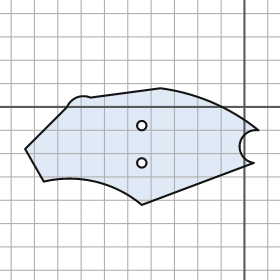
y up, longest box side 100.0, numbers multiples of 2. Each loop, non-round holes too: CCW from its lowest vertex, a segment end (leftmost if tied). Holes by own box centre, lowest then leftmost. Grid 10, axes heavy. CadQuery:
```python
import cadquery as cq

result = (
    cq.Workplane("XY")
    .moveTo(-44.0, -42.0)
    .lineTo(4.0, -24.0)
    .threePointArc((-2.0, -16.0), (6.0, -10.0))
    .threePointArc((-14.0, 2.0), (-36.0, 8.0))
    .lineTo(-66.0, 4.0)
    .threePointArc((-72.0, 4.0), (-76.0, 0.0))
    .lineTo(-94.0, -18.0)
    .lineTo(-86.0, -32.0)
    .threePointArc((-64.0, -32.0), (-44.0, -42.0))
    .close()
    .moveTo(-44.0, -24.0)
    .circle(2.0)
    .moveTo(-44.0, -8.0)
    .circle(2.0)
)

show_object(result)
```